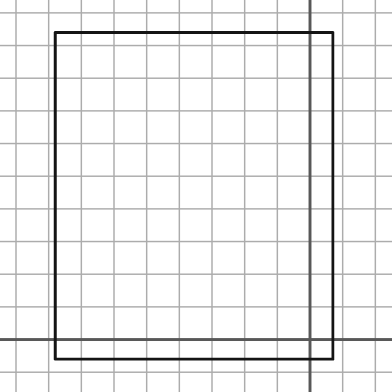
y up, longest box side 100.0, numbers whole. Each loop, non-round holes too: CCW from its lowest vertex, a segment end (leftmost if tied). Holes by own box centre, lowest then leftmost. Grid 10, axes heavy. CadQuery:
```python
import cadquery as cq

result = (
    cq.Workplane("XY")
    .moveTo(-78.0, -6.0)
    .lineTo(7.0, -6.0)
    .lineTo(7.0, 94.0)
    .lineTo(-78.0, 94.0)
    .close()
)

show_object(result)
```